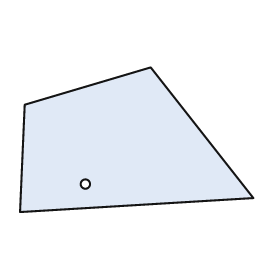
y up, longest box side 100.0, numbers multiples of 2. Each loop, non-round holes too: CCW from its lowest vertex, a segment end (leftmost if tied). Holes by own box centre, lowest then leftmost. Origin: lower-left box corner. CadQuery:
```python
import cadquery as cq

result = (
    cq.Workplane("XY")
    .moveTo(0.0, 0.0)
    .lineTo(100.0, 6.0)
    .lineTo(56.0, 62.0)
    .lineTo(2.0, 46.0)
    .close()
    .moveTo(28.0, 12.0)
    .circle(2.0)
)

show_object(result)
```